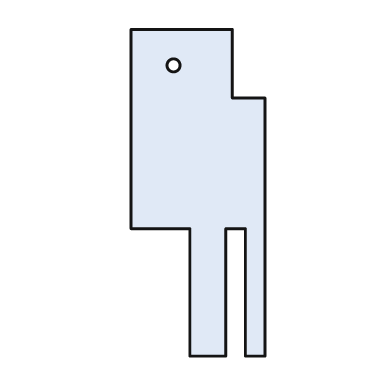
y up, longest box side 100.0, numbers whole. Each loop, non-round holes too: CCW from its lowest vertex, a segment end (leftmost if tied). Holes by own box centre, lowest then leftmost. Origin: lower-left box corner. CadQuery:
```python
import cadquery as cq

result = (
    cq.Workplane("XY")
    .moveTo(18.0, 0.0)
    .lineTo(29.0, 0.0)
    .lineTo(29.0, 39.0)
    .lineTo(35.0, 39.0)
    .lineTo(35.0, 0.0)
    .lineTo(41.0, 0.0)
    .lineTo(41.0, 79.0)
    .lineTo(31.0, 79.0)
    .lineTo(31.0, 100.0)
    .lineTo(0.0, 100.0)
    .lineTo(0.0, 39.0)
    .lineTo(18.0, 39.0)
    .close()
    .moveTo(13.0, 89.0)
    .circle(2.0)
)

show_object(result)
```